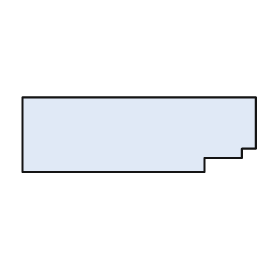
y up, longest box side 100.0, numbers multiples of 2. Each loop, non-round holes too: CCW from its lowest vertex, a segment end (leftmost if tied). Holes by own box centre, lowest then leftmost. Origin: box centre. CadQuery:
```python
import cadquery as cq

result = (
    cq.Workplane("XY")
    .moveTo(-50.0, -16.0)
    .lineTo(28.0, -16.0)
    .lineTo(28.0, -10.0)
    .lineTo(44.0, -10.0)
    .lineTo(44.0, -6.0)
    .lineTo(50.0, -6.0)
    .lineTo(50.0, 16.0)
    .lineTo(-50.0, 16.0)
    .close()
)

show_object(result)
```